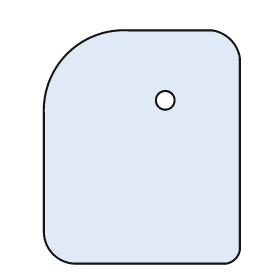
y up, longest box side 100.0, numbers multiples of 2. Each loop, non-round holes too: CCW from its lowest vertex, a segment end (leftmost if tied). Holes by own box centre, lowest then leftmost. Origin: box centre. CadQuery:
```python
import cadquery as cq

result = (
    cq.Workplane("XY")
    .moveTo(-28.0, -50.0)
    .lineTo(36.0, -50.0)
    .threePointArc((40.0, -48.0), (42.0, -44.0))
    .lineTo(42.0, 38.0)
    .threePointArc((38.0, 46.0), (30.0, 50.0))
    .lineTo(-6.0, 50.0)
    .threePointArc((-32.0, 40.0), (-42.0, 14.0))
    .lineTo(-42.0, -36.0)
    .threePointArc((-38.0, -46.0), (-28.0, -50.0))
    .close()
    .moveTo(10.0, 20.0)
    .circle(4.0)
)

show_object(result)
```